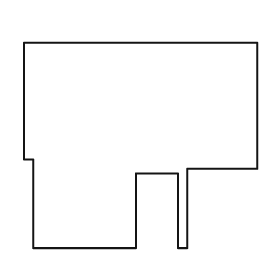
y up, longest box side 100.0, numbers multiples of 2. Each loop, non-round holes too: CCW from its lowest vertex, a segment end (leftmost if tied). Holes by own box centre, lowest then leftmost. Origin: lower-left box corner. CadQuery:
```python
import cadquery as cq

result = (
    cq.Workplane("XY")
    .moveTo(4.0, 0.0)
    .lineTo(48.0, 0.0)
    .lineTo(48.0, 32.0)
    .lineTo(66.0, 32.0)
    .lineTo(66.0, 0.0)
    .lineTo(70.0, 0.0)
    .lineTo(70.0, 34.0)
    .lineTo(100.0, 34.0)
    .lineTo(100.0, 88.0)
    .lineTo(0.0, 88.0)
    .lineTo(0.0, 38.0)
    .lineTo(4.0, 38.0)
    .close()
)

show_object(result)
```